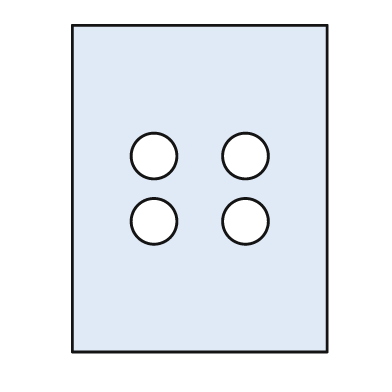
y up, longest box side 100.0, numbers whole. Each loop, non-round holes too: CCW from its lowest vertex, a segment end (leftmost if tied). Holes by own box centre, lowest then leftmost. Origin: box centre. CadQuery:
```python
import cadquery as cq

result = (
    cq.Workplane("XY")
    .moveTo(-39.0, -50.0)
    .lineTo(39.0, -50.0)
    .lineTo(39.0, 50.0)
    .lineTo(-39.0, 50.0)
    .close()
    .moveTo(-14.0, -10.0)
    .circle(7.0)
    .moveTo(14.0, -10.0)
    .circle(7.0)
    .moveTo(-14.0, 10.0)
    .circle(7.0)
    .moveTo(14.0, 10.0)
    .circle(7.0)
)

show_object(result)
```